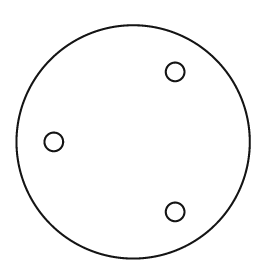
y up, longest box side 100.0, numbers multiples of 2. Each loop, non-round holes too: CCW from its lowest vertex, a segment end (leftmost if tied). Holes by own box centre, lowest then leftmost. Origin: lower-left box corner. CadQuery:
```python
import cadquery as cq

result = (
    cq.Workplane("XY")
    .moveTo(50.0, 50.0)
    .circle(50.0)
    .moveTo(68.0, 20.0)
    .circle(4.0)
    .moveTo(16.0, 50.0)
    .circle(4.0)
    .moveTo(68.0, 80.0)
    .circle(4.0)
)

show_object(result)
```